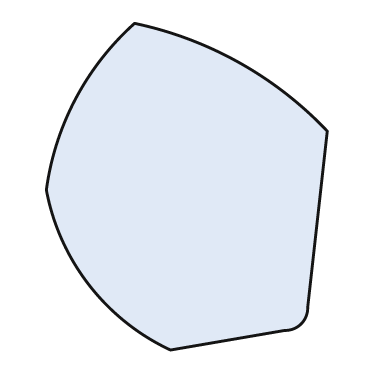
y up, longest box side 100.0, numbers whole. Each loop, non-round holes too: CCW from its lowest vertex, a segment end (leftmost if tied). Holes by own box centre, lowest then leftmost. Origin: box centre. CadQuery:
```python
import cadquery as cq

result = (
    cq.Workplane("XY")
    .moveTo(-5.0, -50.0)
    .lineTo(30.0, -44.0)
    .threePointArc((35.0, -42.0), (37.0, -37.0))
    .lineTo(43.0, 17.0)
    .threePointArc((16.0, 38.0), (-16.0, 50.0))
    .threePointArc((-34.0, 27.0), (-43.0, -1.0))
    .threePointArc((-30.0, -30.0), (-5.0, -50.0))
    .close()
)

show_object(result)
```